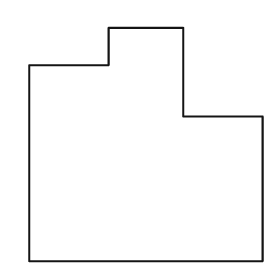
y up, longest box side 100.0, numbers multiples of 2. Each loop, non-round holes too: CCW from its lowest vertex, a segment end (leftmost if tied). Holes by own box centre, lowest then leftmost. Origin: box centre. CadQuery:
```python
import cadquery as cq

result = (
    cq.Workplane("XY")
    .moveTo(-50.0, -50.0)
    .lineTo(50.0, -50.0)
    .lineTo(50.0, 12.0)
    .lineTo(16.0, 12.0)
    .lineTo(16.0, 50.0)
    .lineTo(-16.0, 50.0)
    .lineTo(-16.0, 34.0)
    .lineTo(-50.0, 34.0)
    .close()
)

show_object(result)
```